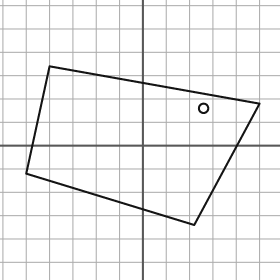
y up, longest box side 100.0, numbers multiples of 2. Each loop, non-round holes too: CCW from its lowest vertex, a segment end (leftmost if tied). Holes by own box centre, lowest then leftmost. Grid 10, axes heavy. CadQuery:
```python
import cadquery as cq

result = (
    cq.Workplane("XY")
    .moveTo(22.0, -34.0)
    .lineTo(50.0, 18.0)
    .lineTo(-40.0, 34.0)
    .lineTo(-50.0, -12.0)
    .close()
    .moveTo(26.0, 16.0)
    .circle(2.0)
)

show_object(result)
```